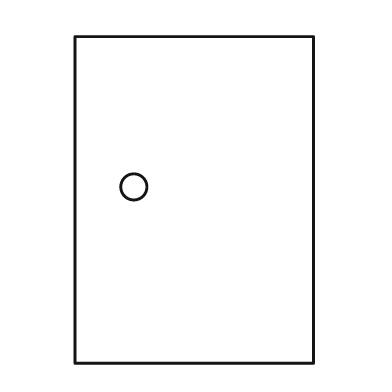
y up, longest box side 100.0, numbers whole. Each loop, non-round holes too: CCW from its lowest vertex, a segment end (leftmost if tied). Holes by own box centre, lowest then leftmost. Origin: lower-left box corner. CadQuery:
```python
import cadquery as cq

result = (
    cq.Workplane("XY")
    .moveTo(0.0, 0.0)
    .lineTo(73.0, 0.0)
    .lineTo(73.0, 100.0)
    .lineTo(0.0, 100.0)
    .close()
    .moveTo(18.0, 54.0)
    .circle(4.0)
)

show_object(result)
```